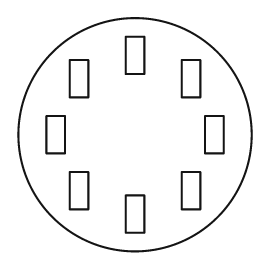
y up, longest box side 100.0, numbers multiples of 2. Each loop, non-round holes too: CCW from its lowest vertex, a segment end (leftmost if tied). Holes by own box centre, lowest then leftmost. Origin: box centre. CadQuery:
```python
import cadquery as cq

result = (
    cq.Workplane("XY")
    .moveTo(0.0, 0.0)
    .circle(50.0)
    .moveTo(-4.0, -42.0)
    .lineTo(4.0, -42.0)
    .lineTo(4.0, -26.0)
    .lineTo(-4.0, -26.0)
    .close()
    .moveTo(-28.0, -32.0)
    .lineTo(-20.0, -32.0)
    .lineTo(-20.0, -16.0)
    .lineTo(-28.0, -16.0)
    .close()
    .moveTo(20.0, -32.0)
    .lineTo(28.0, -32.0)
    .lineTo(28.0, -16.0)
    .lineTo(20.0, -16.0)
    .close()
    .moveTo(-38.0, -8.0)
    .lineTo(-30.0, -8.0)
    .lineTo(-30.0, 8.0)
    .lineTo(-38.0, 8.0)
    .close()
    .moveTo(30.0, -8.0)
    .lineTo(38.0, -8.0)
    .lineTo(38.0, 8.0)
    .lineTo(30.0, 8.0)
    .close()
    .moveTo(-28.0, 16.0)
    .lineTo(-20.0, 16.0)
    .lineTo(-20.0, 32.0)
    .lineTo(-28.0, 32.0)
    .close()
    .moveTo(20.0, 16.0)
    .lineTo(28.0, 16.0)
    .lineTo(28.0, 32.0)
    .lineTo(20.0, 32.0)
    .close()
    .moveTo(-4.0, 26.0)
    .lineTo(4.0, 26.0)
    .lineTo(4.0, 42.0)
    .lineTo(-4.0, 42.0)
    .close()
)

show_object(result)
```